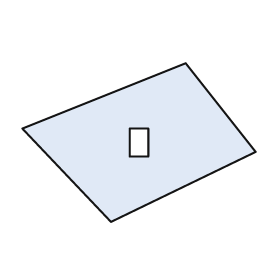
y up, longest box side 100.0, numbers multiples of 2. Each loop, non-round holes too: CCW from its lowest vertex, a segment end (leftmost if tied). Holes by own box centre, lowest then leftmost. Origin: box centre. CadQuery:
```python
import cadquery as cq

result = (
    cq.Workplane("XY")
    .moveTo(-12.0, -34.0)
    .lineTo(50.0, -4.0)
    .lineTo(20.0, 34.0)
    .lineTo(-50.0, 6.0)
    .close()
    .moveTo(-4.0, -6.0)
    .lineTo(4.0, -6.0)
    .lineTo(4.0, 6.0)
    .lineTo(-4.0, 6.0)
    .close()
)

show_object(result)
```